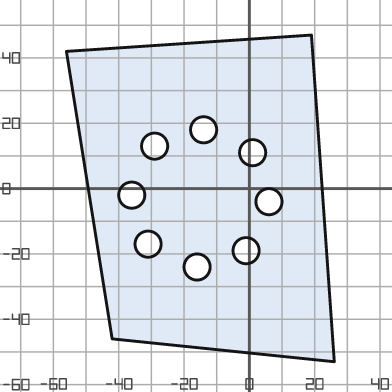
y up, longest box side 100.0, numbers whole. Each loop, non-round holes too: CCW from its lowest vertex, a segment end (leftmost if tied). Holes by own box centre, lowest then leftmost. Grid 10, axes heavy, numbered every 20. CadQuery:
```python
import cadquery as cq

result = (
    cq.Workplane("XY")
    .moveTo(26.0, -53.0)
    .lineTo(19.0, 47.0)
    .lineTo(-56.0, 42.0)
    .lineTo(-42.0, -46.0)
    .close()
    .moveTo(-16.0, -24.0)
    .circle(4.0)
    .moveTo(-1.0, -19.0)
    .circle(4.0)
    .moveTo(-31.0, -17.0)
    .circle(4.0)
    .moveTo(6.0, -4.0)
    .circle(4.0)
    .moveTo(-36.0, -2.0)
    .circle(4.0)
    .moveTo(1.0, 11.0)
    .circle(4.0)
    .moveTo(-29.0, 13.0)
    .circle(4.0)
    .moveTo(-14.0, 18.0)
    .circle(4.0)
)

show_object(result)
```